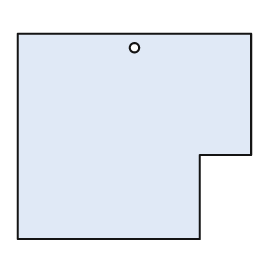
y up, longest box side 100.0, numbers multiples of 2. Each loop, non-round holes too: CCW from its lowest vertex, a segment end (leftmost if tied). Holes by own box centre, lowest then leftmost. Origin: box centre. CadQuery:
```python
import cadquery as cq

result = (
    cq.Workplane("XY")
    .moveTo(-50.0, -44.0)
    .lineTo(28.0, -44.0)
    .lineTo(28.0, -8.0)
    .lineTo(50.0, -8.0)
    .lineTo(50.0, 44.0)
    .lineTo(-50.0, 44.0)
    .close()
    .moveTo(0.0, 38.0)
    .circle(2.0)
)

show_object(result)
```